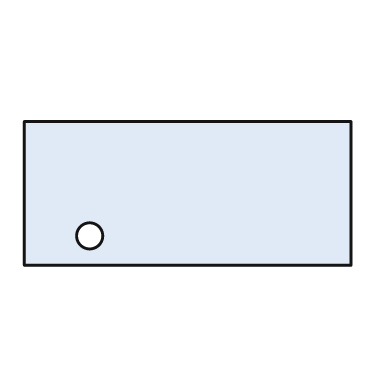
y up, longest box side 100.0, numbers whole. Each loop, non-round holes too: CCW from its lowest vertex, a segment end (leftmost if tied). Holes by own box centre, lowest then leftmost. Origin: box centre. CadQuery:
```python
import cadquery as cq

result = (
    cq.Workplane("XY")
    .moveTo(-50.0, -22.0)
    .lineTo(50.0, -22.0)
    .lineTo(50.0, 22.0)
    .lineTo(-50.0, 22.0)
    .close()
    .moveTo(-30.0, -13.0)
    .circle(4.0)
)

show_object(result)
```